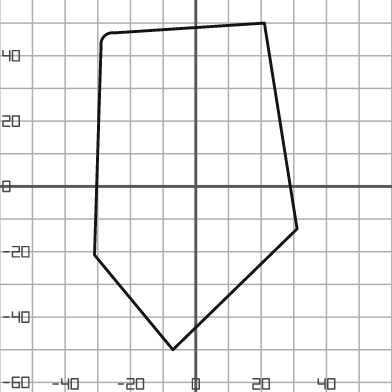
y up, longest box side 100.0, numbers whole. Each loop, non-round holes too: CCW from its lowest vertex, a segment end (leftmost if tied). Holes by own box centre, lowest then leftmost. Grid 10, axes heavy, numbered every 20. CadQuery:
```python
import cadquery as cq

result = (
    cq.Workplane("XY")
    .moveTo(-7.0, -50.0)
    .lineTo(31.0, -13.0)
    .lineTo(21.0, 50.0)
    .lineTo(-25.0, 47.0)
    .threePointArc((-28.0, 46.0), (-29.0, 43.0))
    .lineTo(-31.0, -21.0)
    .close()
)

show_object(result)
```